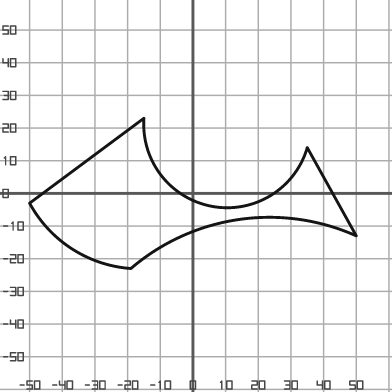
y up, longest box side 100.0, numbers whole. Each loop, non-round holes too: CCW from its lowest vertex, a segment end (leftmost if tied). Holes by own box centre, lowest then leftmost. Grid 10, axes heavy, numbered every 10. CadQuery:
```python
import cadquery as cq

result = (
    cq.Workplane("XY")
    .moveTo(-19.0, -23.0)
    .threePointArc((14.0, -8.0), (50.0, -13.0))
    .lineTo(35.0, 14.0)
    .threePointArc((6.0, -4.0), (-15.0, 23.0))
    .lineTo(-50.0, -3.0)
    .threePointArc((-37.0, -17.0), (-19.0, -23.0))
    .close()
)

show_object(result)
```